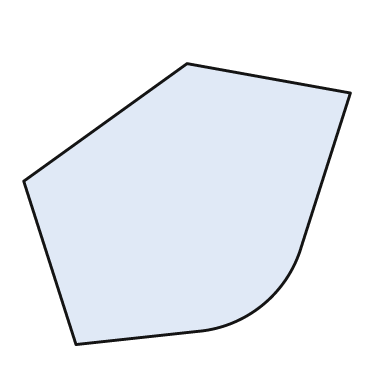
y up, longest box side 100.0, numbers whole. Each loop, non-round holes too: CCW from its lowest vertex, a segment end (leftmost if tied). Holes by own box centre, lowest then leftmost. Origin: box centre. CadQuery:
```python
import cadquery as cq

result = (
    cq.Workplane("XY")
    .moveTo(-34.0, -43.0)
    .lineTo(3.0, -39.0)
    .threePointArc((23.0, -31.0), (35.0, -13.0))
    .lineTo(50.0, 34.0)
    .lineTo(0.0, 43.0)
    .lineTo(-50.0, 7.0)
    .close()
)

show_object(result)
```